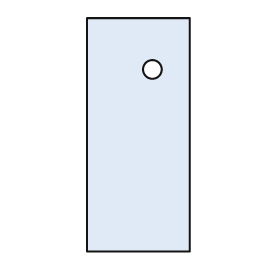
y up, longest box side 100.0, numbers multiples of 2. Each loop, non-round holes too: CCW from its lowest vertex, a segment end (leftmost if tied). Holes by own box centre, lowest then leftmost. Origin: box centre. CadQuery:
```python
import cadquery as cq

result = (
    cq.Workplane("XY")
    .moveTo(-22.0, -50.0)
    .lineTo(22.0, -50.0)
    .lineTo(22.0, 50.0)
    .lineTo(-22.0, 50.0)
    .close()
    .moveTo(6.0, 28.0)
    .circle(4.0)
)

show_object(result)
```